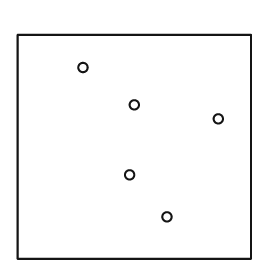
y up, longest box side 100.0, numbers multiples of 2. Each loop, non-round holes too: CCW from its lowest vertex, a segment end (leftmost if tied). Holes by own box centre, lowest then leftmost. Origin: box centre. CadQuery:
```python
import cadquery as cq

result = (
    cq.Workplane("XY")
    .moveTo(-50.0, -48.0)
    .lineTo(50.0, -48.0)
    .lineTo(50.0, 48.0)
    .lineTo(-50.0, 48.0)
    .close()
    .moveTo(14.0, -30.0)
    .circle(2.0)
    .moveTo(-2.0, -12.0)
    .circle(2.0)
    .moveTo(36.0, 12.0)
    .circle(2.0)
    .moveTo(0.0, 18.0)
    .circle(2.0)
    .moveTo(-22.0, 34.0)
    .circle(2.0)
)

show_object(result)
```